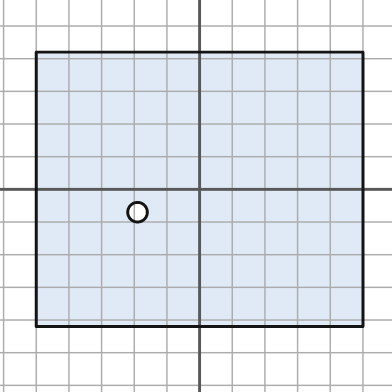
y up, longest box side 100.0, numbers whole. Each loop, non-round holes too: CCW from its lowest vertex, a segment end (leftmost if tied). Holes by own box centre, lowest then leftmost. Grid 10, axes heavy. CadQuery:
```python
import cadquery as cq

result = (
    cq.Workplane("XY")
    .moveTo(-50.0, -42.0)
    .lineTo(50.0, -42.0)
    .lineTo(50.0, 42.0)
    .lineTo(-50.0, 42.0)
    .close()
    .moveTo(-19.0, -7.0)
    .circle(3.0)
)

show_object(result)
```